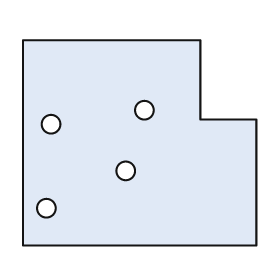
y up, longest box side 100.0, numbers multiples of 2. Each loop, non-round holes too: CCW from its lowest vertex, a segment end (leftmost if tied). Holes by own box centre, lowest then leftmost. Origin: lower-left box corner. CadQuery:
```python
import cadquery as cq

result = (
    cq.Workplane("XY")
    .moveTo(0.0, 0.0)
    .lineTo(100.0, 0.0)
    .lineTo(100.0, 54.0)
    .lineTo(76.0, 54.0)
    .lineTo(76.0, 88.0)
    .lineTo(0.0, 88.0)
    .close()
    .moveTo(10.0, 16.0)
    .circle(4.0)
    .moveTo(44.0, 32.0)
    .circle(4.0)
    .moveTo(12.0, 52.0)
    .circle(4.0)
    .moveTo(52.0, 58.0)
    .circle(4.0)
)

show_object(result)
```